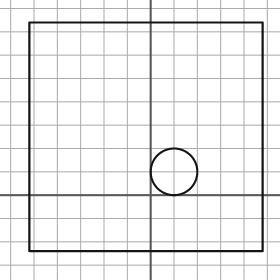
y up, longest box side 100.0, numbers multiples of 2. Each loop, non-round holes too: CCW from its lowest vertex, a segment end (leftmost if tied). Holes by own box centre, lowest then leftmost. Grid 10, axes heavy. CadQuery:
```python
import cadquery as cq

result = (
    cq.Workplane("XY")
    .moveTo(-52.0, -24.0)
    .lineTo(48.0, -24.0)
    .lineTo(48.0, 74.0)
    .lineTo(-52.0, 74.0)
    .close()
    .moveTo(10.0, 10.0)
    .circle(10.0)
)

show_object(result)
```